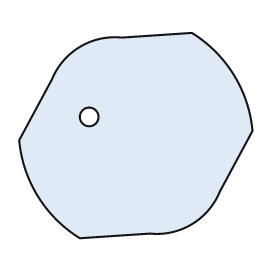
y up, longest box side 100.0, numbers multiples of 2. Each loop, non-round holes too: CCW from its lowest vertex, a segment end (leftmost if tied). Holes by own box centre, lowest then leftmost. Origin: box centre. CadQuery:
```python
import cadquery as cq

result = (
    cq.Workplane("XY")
    .moveTo(-24.0, -44.0)
    .lineTo(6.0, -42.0)
    .threePointArc((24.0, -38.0), (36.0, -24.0))
    .lineTo(50.0, 2.0)
    .threePointArc((42.0, 26.0), (24.0, 44.0))
    .lineTo(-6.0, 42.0)
    .threePointArc((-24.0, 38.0), (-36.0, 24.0))
    .lineTo(-50.0, -2.0)
    .threePointArc((-42.0, -26.0), (-24.0, -44.0))
    .close()
    .moveTo(-20.0, 8.0)
    .circle(4.0)
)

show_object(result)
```